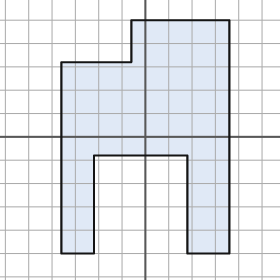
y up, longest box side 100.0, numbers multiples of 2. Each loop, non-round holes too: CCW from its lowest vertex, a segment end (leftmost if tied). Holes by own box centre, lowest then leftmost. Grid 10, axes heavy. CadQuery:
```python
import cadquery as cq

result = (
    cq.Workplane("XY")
    .moveTo(-36.0, -50.0)
    .lineTo(-22.0, -50.0)
    .lineTo(-22.0, -8.0)
    .lineTo(18.0, -8.0)
    .lineTo(18.0, -50.0)
    .lineTo(36.0, -50.0)
    .lineTo(36.0, 50.0)
    .lineTo(-6.0, 50.0)
    .lineTo(-6.0, 32.0)
    .lineTo(-36.0, 32.0)
    .close()
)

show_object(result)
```